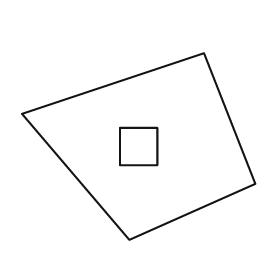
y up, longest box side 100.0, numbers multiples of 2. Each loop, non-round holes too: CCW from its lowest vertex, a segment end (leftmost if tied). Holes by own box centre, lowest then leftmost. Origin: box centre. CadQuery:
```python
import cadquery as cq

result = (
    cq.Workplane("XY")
    .moveTo(-4.0, -40.0)
    .lineTo(50.0, -16.0)
    .lineTo(28.0, 40.0)
    .lineTo(-50.0, 14.0)
    .close()
    .moveTo(-8.0, -8.0)
    .lineTo(8.0, -8.0)
    .lineTo(8.0, 8.0)
    .lineTo(-8.0, 8.0)
    .close()
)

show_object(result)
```